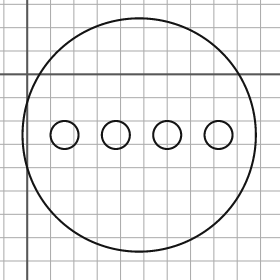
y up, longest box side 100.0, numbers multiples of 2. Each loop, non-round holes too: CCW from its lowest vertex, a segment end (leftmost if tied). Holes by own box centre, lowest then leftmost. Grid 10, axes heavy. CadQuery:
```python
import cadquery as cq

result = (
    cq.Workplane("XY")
    .moveTo(48.0, -26.0)
    .circle(50.0)
    .moveTo(16.0, -26.0)
    .circle(6.0)
    .moveTo(38.0, -26.0)
    .circle(6.0)
    .moveTo(60.0, -26.0)
    .circle(6.0)
    .moveTo(82.0, -26.0)
    .circle(6.0)
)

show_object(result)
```